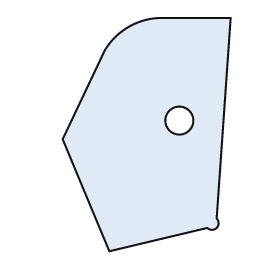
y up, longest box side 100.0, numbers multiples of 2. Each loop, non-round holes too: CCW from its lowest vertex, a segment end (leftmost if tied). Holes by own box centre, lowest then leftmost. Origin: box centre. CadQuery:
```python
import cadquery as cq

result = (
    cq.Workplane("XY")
    .moveTo(-16.0, -50.0)
    .lineTo(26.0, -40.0)
    .threePointArc((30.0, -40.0), (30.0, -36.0))
    .lineTo(36.0, 50.0)
    .lineTo(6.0, 50.0)
    .threePointArc((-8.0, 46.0), (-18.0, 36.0))
    .lineTo(-36.0, -2.0)
    .close()
    .moveTo(14.0, 6.0)
    .circle(6.0)
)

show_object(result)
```